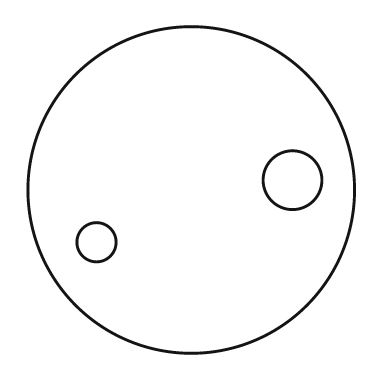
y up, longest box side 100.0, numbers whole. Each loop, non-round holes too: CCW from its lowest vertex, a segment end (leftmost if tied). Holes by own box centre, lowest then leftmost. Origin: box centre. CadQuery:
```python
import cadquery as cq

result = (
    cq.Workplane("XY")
    .moveTo(0.0, 0.0)
    .circle(50.0)
    .moveTo(-29.0, -16.0)
    .circle(6.0)
    .moveTo(31.0, 3.0)
    .circle(9.0)
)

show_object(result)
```